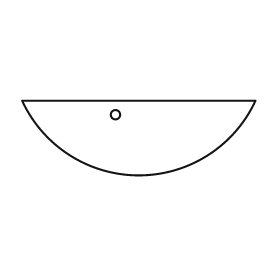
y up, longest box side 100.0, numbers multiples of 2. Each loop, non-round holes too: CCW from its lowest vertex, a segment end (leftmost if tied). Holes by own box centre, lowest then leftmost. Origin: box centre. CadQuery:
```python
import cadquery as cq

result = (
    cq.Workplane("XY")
    .moveTo(-50.0, 16.0)
    .threePointArc((0.0, -16.0), (50.0, 16.0))
    .close()
    .moveTo(-10.0, 10.0)
    .circle(2.0)
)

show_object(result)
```